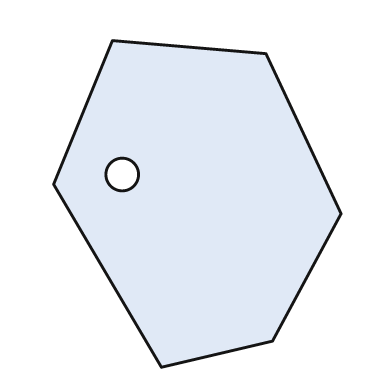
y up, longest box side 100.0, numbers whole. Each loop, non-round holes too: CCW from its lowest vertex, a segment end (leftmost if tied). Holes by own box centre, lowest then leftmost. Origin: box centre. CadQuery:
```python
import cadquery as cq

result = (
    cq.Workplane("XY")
    .moveTo(-11.0, -50.0)
    .lineTo(23.0, -42.0)
    .lineTo(44.0, -3.0)
    .lineTo(21.0, 46.0)
    .lineTo(-26.0, 50.0)
    .lineTo(-44.0, 6.0)
    .close()
    .moveTo(-23.0, 9.0)
    .circle(5.0)
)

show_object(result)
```